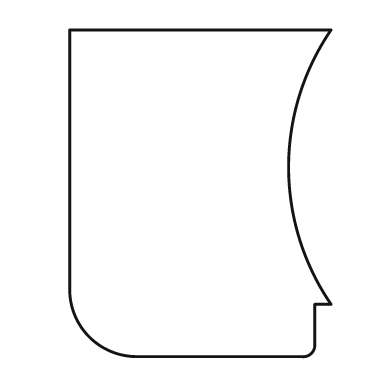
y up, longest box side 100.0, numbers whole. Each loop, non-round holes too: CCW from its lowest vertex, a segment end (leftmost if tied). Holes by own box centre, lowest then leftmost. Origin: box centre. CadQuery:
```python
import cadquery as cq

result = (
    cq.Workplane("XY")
    .moveTo(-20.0, -50.0)
    .lineTo(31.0, -50.0)
    .threePointArc((34.0, -49.0), (35.0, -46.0))
    .lineTo(35.0, -34.0)
    .lineTo(40.0, -34.0)
    .threePointArc((27.0, 8.0), (40.0, 50.0))
    .lineTo(-40.0, 50.0)
    .lineTo(-40.0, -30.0)
    .threePointArc((-34.0, -44.0), (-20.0, -50.0))
    .close()
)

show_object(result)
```